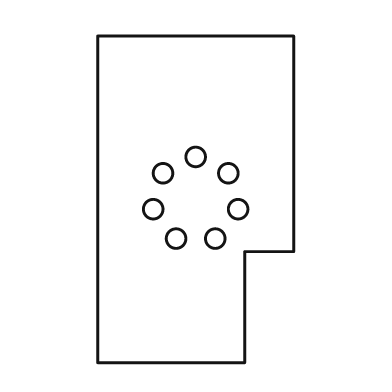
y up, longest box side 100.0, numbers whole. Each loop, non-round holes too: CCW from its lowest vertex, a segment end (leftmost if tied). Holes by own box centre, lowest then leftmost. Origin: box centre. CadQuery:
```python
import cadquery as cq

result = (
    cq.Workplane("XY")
    .moveTo(-30.0, -50.0)
    .lineTo(15.0, -50.0)
    .lineTo(15.0, -16.0)
    .lineTo(30.0, -16.0)
    .lineTo(30.0, 50.0)
    .lineTo(-30.0, 50.0)
    .close()
    .moveTo(-6.0, -12.0)
    .circle(3.0)
    .moveTo(6.0, -12.0)
    .circle(3.0)
    .moveTo(-13.0, -3.0)
    .circle(3.0)
    .moveTo(13.0, -3.0)
    .circle(3.0)
    .moveTo(-10.0, 8.0)
    .circle(3.0)
    .moveTo(10.0, 8.0)
    .circle(3.0)
    .moveTo(0.0, 13.0)
    .circle(3.0)
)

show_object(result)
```